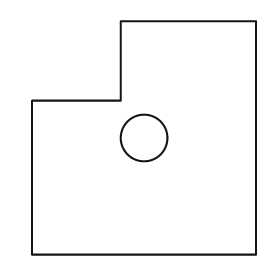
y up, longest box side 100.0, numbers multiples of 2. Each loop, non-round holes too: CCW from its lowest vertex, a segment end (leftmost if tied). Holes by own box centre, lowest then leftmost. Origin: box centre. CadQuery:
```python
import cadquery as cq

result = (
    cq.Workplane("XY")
    .moveTo(-48.0, -50.0)
    .lineTo(48.0, -50.0)
    .lineTo(48.0, 50.0)
    .lineTo(-10.0, 50.0)
    .lineTo(-10.0, 16.0)
    .lineTo(-48.0, 16.0)
    .close()
    .moveTo(0.0, 0.0)
    .circle(10.0)
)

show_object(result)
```